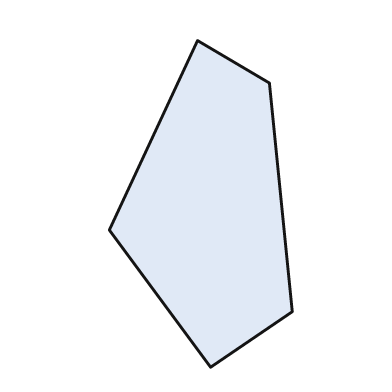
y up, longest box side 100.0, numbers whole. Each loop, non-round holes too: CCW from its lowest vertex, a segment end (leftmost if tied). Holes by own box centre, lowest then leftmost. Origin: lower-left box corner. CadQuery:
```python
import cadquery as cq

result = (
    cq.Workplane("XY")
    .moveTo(31.0, 0.0)
    .lineTo(56.0, 17.0)
    .lineTo(49.0, 87.0)
    .lineTo(27.0, 100.0)
    .lineTo(0.0, 42.0)
    .close()
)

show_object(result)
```